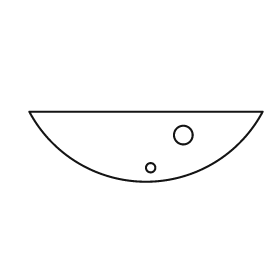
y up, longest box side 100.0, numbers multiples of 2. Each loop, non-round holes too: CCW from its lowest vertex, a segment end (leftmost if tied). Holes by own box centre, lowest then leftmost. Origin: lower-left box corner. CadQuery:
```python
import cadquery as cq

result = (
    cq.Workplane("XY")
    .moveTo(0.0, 30.0)
    .threePointArc((50.0, 0.0), (100.0, 30.0))
    .close()
    .moveTo(52.0, 6.0)
    .circle(2.0)
    .moveTo(66.0, 20.0)
    .circle(4.0)
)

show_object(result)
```